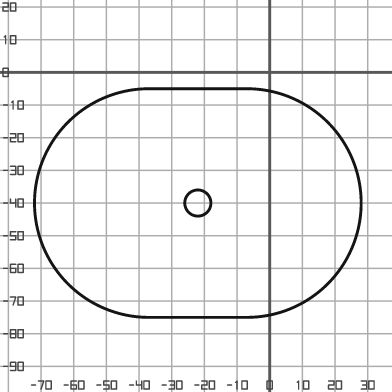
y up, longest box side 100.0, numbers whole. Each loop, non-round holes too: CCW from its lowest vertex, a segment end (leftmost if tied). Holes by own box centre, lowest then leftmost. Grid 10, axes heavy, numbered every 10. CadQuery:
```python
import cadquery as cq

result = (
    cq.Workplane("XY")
    .moveTo(-37.0, -75.0)
    .lineTo(-7.0, -75.0)
    .threePointArc((28.0, -40.0), (-7.0, -5.0))
    .lineTo(-37.0, -5.0)
    .threePointArc((-72.0, -40.0), (-37.0, -75.0))
    .close()
    .moveTo(-22.0, -40.0)
    .circle(4.0)
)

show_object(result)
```